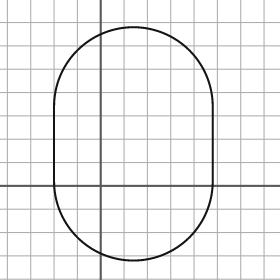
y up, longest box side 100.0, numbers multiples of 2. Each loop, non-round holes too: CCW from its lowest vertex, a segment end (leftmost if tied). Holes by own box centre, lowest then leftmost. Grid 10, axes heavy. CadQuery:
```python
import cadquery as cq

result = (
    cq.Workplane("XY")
    .moveTo(-20.0, 2.0)
    .threePointArc((14.0, -32.0), (48.0, 2.0))
    .lineTo(48.0, 34.0)
    .threePointArc((14.0, 68.0), (-20.0, 34.0))
    .close()
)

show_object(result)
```